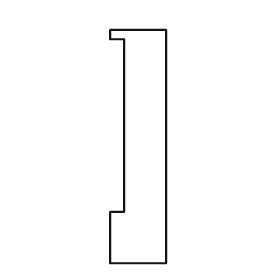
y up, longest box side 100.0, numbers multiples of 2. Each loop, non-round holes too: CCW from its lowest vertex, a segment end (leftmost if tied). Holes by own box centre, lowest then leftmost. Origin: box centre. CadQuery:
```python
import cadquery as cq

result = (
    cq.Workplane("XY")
    .moveTo(-12.0, -50.0)
    .lineTo(12.0, -50.0)
    .lineTo(12.0, 50.0)
    .lineTo(-12.0, 50.0)
    .lineTo(-12.0, 46.0)
    .lineTo(-6.0, 46.0)
    .lineTo(-6.0, -28.0)
    .lineTo(-12.0, -28.0)
    .close()
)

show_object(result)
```